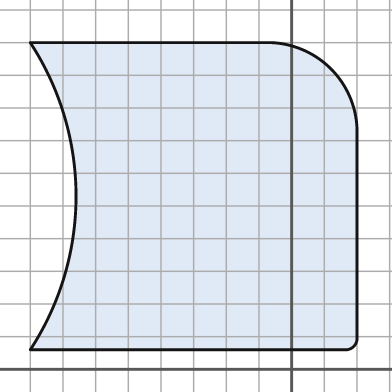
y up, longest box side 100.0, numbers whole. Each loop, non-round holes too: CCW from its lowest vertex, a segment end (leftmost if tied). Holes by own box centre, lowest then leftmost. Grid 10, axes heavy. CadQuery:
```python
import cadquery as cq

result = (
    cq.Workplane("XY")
    .moveTo(-80.0, 6.0)
    .lineTo(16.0, 6.0)
    .threePointArc((19.0, 7.0), (20.0, 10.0))
    .lineTo(20.0, 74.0)
    .threePointArc((12.0, 92.0), (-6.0, 100.0))
    .lineTo(-80.0, 100.0)
    .threePointArc((-66.0, 53.0), (-80.0, 6.0))
    .close()
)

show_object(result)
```